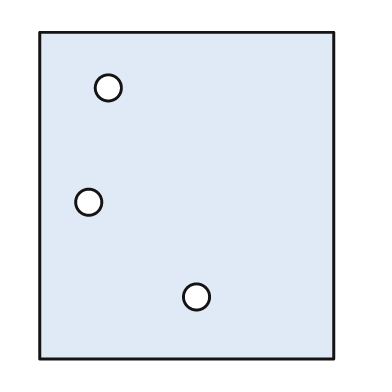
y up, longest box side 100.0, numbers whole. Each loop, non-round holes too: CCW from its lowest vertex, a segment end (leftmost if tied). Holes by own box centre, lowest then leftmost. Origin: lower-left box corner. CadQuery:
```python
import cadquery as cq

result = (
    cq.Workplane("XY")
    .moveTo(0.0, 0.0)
    .lineTo(90.0, 0.0)
    .lineTo(90.0, 100.0)
    .lineTo(0.0, 100.0)
    .close()
    .moveTo(48.0, 19.0)
    .circle(4.0)
    .moveTo(15.0, 48.0)
    .circle(4.0)
    .moveTo(21.0, 83.0)
    .circle(4.0)
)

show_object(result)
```